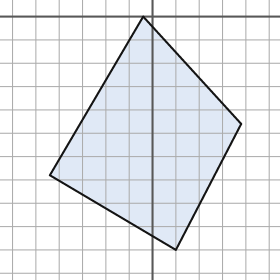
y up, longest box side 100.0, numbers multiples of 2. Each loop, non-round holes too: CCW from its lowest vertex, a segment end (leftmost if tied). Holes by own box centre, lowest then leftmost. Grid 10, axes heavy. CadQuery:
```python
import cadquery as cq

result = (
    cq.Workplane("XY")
    .moveTo(10.0, -100.0)
    .lineTo(38.0, -46.0)
    .lineTo(-4.0, 0.0)
    .lineTo(-44.0, -68.0)
    .close()
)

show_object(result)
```